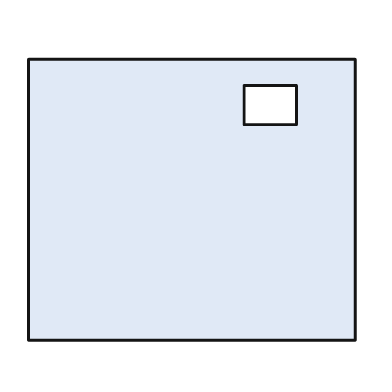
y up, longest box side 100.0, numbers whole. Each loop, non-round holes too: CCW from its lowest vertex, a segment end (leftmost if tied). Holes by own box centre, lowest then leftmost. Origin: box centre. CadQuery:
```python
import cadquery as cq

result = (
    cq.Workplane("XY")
    .moveTo(-50.0, -43.0)
    .lineTo(50.0, -43.0)
    .lineTo(50.0, 43.0)
    .lineTo(-50.0, 43.0)
    .close()
    .moveTo(16.0, 23.0)
    .lineTo(32.0, 23.0)
    .lineTo(32.0, 35.0)
    .lineTo(16.0, 35.0)
    .close()
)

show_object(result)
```